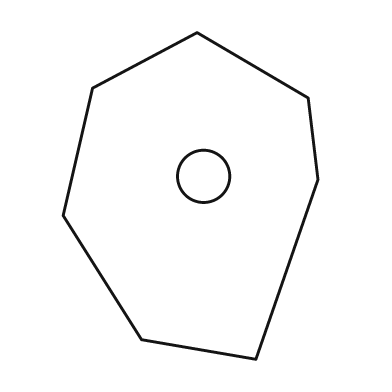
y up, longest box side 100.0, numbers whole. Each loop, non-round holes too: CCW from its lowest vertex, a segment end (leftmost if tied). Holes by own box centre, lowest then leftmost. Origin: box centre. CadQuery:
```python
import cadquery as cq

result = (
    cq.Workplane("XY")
    .moveTo(20.0, -50.0)
    .lineTo(39.0, 5.0)
    .lineTo(36.0, 30.0)
    .lineTo(2.0, 50.0)
    .lineTo(-30.0, 33.0)
    .lineTo(-39.0, -6.0)
    .lineTo(-15.0, -44.0)
    .close()
    .moveTo(4.0, 6.0)
    .circle(8.0)
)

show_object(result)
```